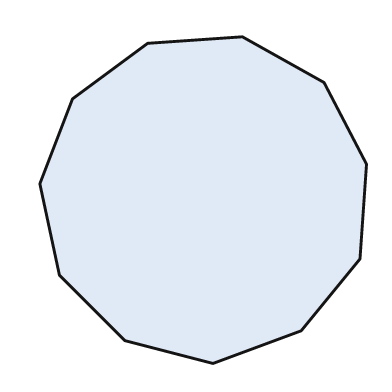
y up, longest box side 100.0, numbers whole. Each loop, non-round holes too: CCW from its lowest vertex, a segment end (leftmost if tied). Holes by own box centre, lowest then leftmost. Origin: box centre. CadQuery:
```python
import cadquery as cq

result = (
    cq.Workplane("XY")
    .moveTo(3.0, -50.0)
    .lineTo(30.0, -40.0)
    .lineTo(48.0, -18.0)
    .lineTo(50.0, 11.0)
    .lineTo(37.0, 36.0)
    .lineTo(12.0, 50.0)
    .lineTo(-17.0, 48.0)
    .lineTo(-40.0, 31.0)
    .lineTo(-50.0, 5.0)
    .lineTo(-44.0, -23.0)
    .lineTo(-24.0, -43.0)
    .close()
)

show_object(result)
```